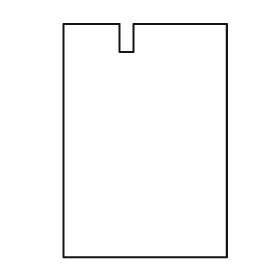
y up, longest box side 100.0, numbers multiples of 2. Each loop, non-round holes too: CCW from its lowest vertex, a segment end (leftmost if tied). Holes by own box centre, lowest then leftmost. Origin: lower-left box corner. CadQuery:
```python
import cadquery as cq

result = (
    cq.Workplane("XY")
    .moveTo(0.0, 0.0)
    .lineTo(70.0, 0.0)
    .lineTo(70.0, 100.0)
    .lineTo(30.0, 100.0)
    .lineTo(30.0, 88.0)
    .lineTo(24.0, 88.0)
    .lineTo(24.0, 100.0)
    .lineTo(0.0, 100.0)
    .close()
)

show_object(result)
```